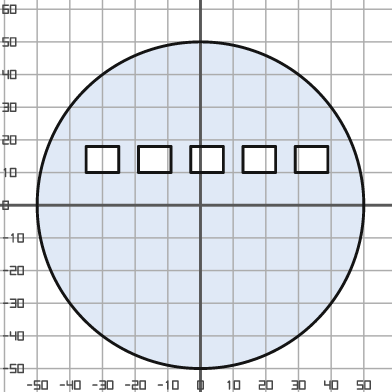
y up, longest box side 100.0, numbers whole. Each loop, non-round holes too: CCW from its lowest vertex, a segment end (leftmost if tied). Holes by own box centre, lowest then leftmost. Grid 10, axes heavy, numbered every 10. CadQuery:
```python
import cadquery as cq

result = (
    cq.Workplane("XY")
    .moveTo(0.0, 0.0)
    .circle(50.0)
    .moveTo(-35.0, 10.0)
    .lineTo(-25.0, 10.0)
    .lineTo(-25.0, 18.0)
    .lineTo(-35.0, 18.0)
    .close()
    .moveTo(-19.0, 10.0)
    .lineTo(-9.0, 10.0)
    .lineTo(-9.0, 18.0)
    .lineTo(-19.0, 18.0)
    .close()
    .moveTo(-3.0, 10.0)
    .lineTo(7.0, 10.0)
    .lineTo(7.0, 18.0)
    .lineTo(-3.0, 18.0)
    .close()
    .moveTo(13.0, 10.0)
    .lineTo(23.0, 10.0)
    .lineTo(23.0, 18.0)
    .lineTo(13.0, 18.0)
    .close()
    .moveTo(29.0, 10.0)
    .lineTo(39.0, 10.0)
    .lineTo(39.0, 18.0)
    .lineTo(29.0, 18.0)
    .close()
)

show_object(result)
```